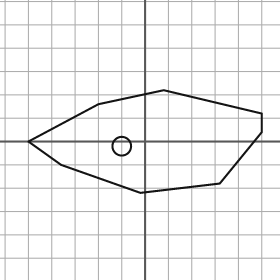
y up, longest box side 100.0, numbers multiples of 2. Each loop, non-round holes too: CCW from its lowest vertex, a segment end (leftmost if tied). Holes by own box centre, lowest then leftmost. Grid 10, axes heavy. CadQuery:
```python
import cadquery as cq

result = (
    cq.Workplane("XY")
    .moveTo(-2.0, -22.0)
    .lineTo(32.0, -18.0)
    .lineTo(50.0, 4.0)
    .lineTo(50.0, 12.0)
    .lineTo(8.0, 22.0)
    .lineTo(-20.0, 16.0)
    .lineTo(-50.0, 0.0)
    .lineTo(-36.0, -10.0)
    .close()
    .moveTo(-10.0, -2.0)
    .circle(4.0)
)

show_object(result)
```